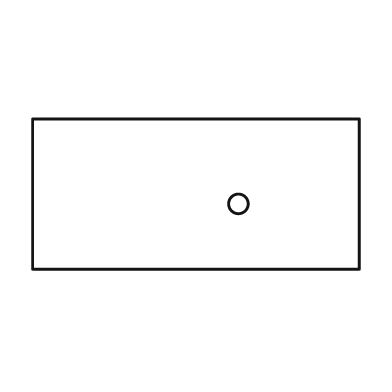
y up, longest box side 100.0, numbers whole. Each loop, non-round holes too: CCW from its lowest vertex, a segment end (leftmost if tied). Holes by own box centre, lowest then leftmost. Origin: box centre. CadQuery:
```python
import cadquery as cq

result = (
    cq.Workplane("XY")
    .moveTo(-50.0, -23.0)
    .lineTo(50.0, -23.0)
    .lineTo(50.0, 23.0)
    .lineTo(-50.0, 23.0)
    .close()
    .moveTo(13.0, -3.0)
    .circle(3.0)
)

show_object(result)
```